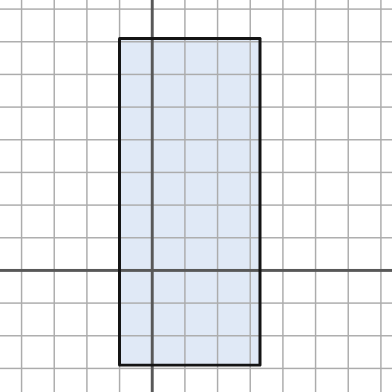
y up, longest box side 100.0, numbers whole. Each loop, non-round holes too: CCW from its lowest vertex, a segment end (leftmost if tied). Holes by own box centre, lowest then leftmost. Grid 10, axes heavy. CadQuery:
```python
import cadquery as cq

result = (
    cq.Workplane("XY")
    .moveTo(-10.0, -29.0)
    .lineTo(33.0, -29.0)
    .lineTo(33.0, 71.0)
    .lineTo(-10.0, 71.0)
    .close()
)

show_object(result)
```